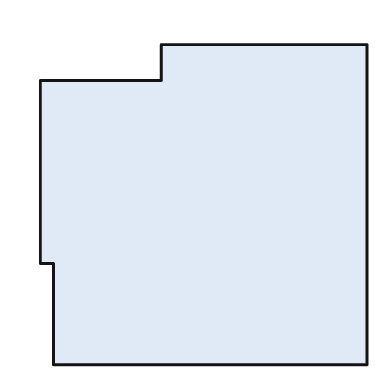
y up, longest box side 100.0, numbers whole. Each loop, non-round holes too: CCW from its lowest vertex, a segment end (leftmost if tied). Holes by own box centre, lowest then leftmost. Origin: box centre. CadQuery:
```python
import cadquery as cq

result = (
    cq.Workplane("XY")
    .moveTo(-46.0, -49.0)
    .lineTo(50.0, -49.0)
    .lineTo(50.0, 49.0)
    .lineTo(-13.0, 49.0)
    .lineTo(-13.0, 38.0)
    .lineTo(-50.0, 38.0)
    .lineTo(-50.0, -18.0)
    .lineTo(-46.0, -18.0)
    .close()
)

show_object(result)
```